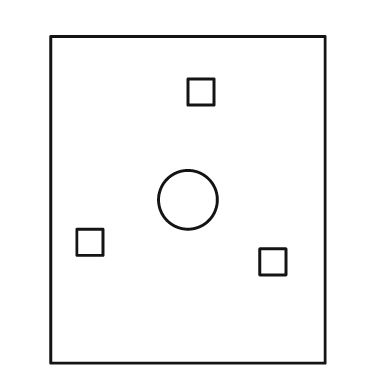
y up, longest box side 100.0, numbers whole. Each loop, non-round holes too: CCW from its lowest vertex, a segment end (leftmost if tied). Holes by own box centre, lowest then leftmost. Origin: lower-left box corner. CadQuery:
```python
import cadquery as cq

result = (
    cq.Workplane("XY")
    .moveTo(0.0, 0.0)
    .lineTo(84.0, 0.0)
    .lineTo(84.0, 100.0)
    .lineTo(0.0, 100.0)
    .close()
    .moveTo(64.0, 27.0)
    .lineTo(72.0, 27.0)
    .lineTo(72.0, 35.0)
    .lineTo(64.0, 35.0)
    .close()
    .moveTo(8.0, 33.0)
    .lineTo(16.0, 33.0)
    .lineTo(16.0, 41.0)
    .lineTo(8.0, 41.0)
    .close()
    .moveTo(42.0, 50.0)
    .circle(9.0)
    .moveTo(42.0, 79.0)
    .lineTo(50.0, 79.0)
    .lineTo(50.0, 87.0)
    .lineTo(42.0, 87.0)
    .close()
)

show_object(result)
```